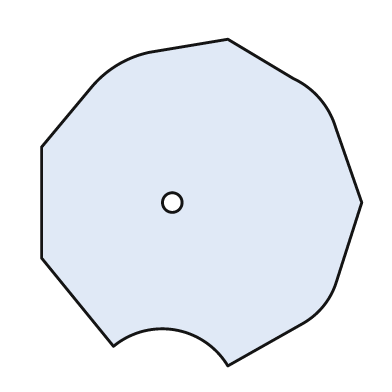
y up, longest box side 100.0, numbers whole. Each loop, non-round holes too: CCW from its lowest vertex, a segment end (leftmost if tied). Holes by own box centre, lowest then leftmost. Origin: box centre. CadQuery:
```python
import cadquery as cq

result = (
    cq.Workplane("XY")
    .moveTo(8.0, -50.0)
    .lineTo(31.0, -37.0)
    .threePointArc((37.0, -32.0), (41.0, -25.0))
    .lineTo(49.0, 0.0)
    .lineTo(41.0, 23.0)
    .threePointArc((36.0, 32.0), (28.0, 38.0))
    .lineTo(8.0, 50.0)
    .lineTo(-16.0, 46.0)
    .threePointArc((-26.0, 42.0), (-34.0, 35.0))
    .lineTo(-49.0, 17.0)
    .lineTo(-49.0, -17.0)
    .lineTo(-27.0, -44.0)
    .threePointArc((-8.0, -39.0), (8.0, -50.0))
    .close()
    .moveTo(-9.0, 0.0)
    .circle(3.0)
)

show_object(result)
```